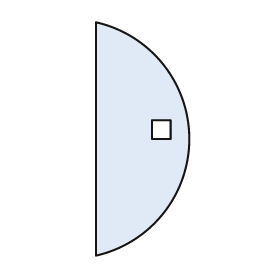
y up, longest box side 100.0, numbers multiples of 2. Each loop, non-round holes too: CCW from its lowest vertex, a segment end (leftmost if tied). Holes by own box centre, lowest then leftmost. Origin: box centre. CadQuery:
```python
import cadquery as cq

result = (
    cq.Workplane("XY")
    .moveTo(-20.0, -50.0)
    .threePointArc((20.0, 0.0), (-20.0, 50.0))
    .close()
    .moveTo(4.0, 0.0)
    .lineTo(12.0, 0.0)
    .lineTo(12.0, 8.0)
    .lineTo(4.0, 8.0)
    .close()
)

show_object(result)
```